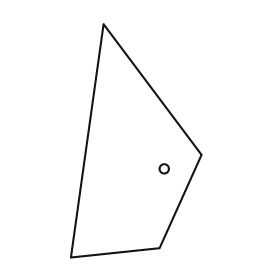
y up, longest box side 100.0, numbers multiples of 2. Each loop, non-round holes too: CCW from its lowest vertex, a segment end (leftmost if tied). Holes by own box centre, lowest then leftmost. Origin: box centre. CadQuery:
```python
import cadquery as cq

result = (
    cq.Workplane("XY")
    .moveTo(-28.0, -50.0)
    .lineTo(10.0, -46.0)
    .lineTo(28.0, -6.0)
    .lineTo(-14.0, 50.0)
    .close()
    .moveTo(12.0, -12.0)
    .circle(2.0)
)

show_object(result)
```